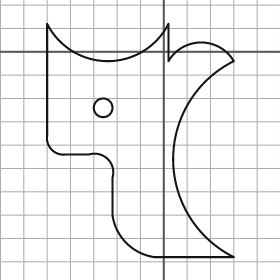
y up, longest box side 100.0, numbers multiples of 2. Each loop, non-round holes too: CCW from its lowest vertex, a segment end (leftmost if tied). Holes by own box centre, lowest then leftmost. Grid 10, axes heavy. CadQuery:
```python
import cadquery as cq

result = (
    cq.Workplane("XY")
    .moveTo(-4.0, -88.0)
    .lineTo(30.0, -88.0)
    .threePointArc((4.0, -46.0), (30.0, -4.0))
    .threePointArc((16.0, 4.0), (2.0, -4.0))
    .lineTo(2.0, 12.0)
    .threePointArc((-24.0, -4.0), (-50.0, 12.0))
    .lineTo(-50.0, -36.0)
    .threePointArc((-48.0, -42.0), (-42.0, -44.0))
    .lineTo(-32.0, -44.0)
    .threePointArc((-24.0, -46.0), (-22.0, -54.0))
    .lineTo(-22.0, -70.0)
    .threePointArc((-16.0, -82.0), (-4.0, -88.0))
    .close()
    .moveTo(-26.0, -24.0)
    .circle(4.0)
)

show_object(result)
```